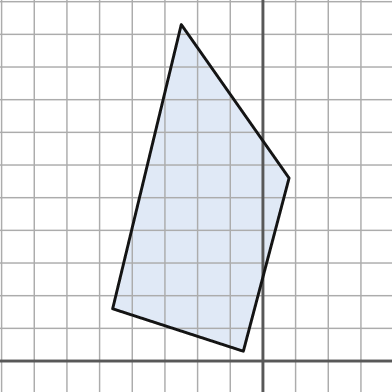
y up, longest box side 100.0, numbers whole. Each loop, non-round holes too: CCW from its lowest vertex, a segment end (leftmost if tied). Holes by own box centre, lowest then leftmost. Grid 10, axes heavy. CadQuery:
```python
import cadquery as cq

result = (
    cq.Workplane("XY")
    .moveTo(-6.0, 3.0)
    .lineTo(8.0, 56.0)
    .lineTo(-25.0, 103.0)
    .lineTo(-46.0, 16.0)
    .close()
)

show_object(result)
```